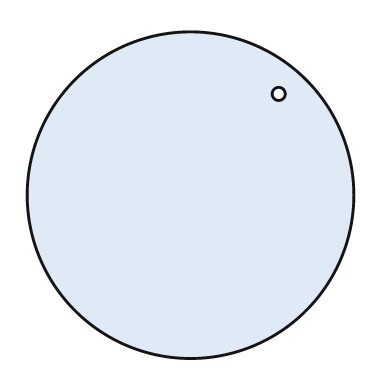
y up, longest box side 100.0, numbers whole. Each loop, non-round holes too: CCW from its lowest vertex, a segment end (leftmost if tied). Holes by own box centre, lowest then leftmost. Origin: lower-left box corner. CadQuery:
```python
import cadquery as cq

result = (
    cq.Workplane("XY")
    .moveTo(50.0, 50.0)
    .circle(50.0)
    .moveTo(77.0, 81.0)
    .circle(2.0)
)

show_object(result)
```